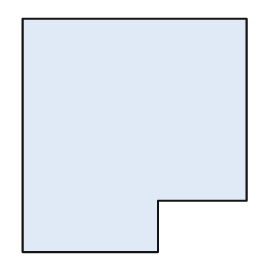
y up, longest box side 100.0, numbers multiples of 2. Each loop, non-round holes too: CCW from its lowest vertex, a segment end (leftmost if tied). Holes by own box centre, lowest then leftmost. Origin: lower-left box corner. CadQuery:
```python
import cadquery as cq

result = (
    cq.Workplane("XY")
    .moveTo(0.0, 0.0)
    .lineTo(58.0, 0.0)
    .lineTo(58.0, 22.0)
    .lineTo(96.0, 22.0)
    .lineTo(96.0, 100.0)
    .lineTo(0.0, 100.0)
    .close()
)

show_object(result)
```